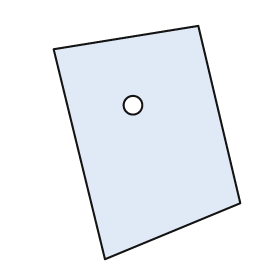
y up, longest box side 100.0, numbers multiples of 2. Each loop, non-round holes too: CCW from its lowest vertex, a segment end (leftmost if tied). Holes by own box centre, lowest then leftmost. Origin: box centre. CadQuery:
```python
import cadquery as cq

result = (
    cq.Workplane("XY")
    .moveTo(-18.0, -50.0)
    .lineTo(40.0, -26.0)
    .lineTo(22.0, 50.0)
    .lineTo(-40.0, 40.0)
    .close()
    .moveTo(-6.0, 16.0)
    .circle(4.0)
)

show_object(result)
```